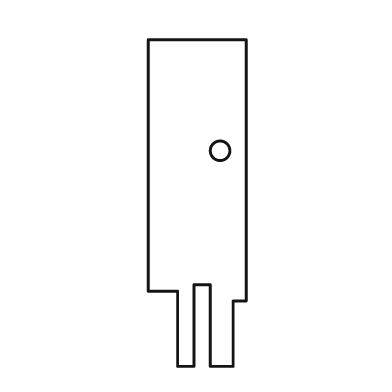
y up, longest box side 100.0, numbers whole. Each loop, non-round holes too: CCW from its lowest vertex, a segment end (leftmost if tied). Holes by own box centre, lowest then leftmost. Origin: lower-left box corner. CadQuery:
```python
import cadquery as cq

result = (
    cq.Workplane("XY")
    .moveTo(9.0, 0.0)
    .lineTo(14.0, 0.0)
    .lineTo(14.0, 25.0)
    .lineTo(19.0, 25.0)
    .lineTo(19.0, 0.0)
    .lineTo(26.0, 0.0)
    .lineTo(26.0, 20.0)
    .lineTo(30.0, 20.0)
    .lineTo(30.0, 100.0)
    .lineTo(0.0, 100.0)
    .lineTo(0.0, 23.0)
    .lineTo(9.0, 23.0)
    .close()
    .moveTo(22.0, 66.0)
    .circle(3.0)
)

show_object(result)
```